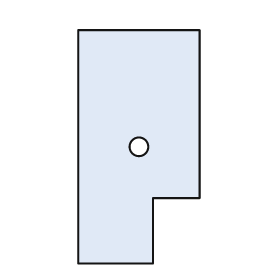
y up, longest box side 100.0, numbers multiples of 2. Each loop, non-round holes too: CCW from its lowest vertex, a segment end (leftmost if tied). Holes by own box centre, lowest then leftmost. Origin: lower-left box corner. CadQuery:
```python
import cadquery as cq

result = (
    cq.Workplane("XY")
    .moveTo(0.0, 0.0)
    .lineTo(32.0, 0.0)
    .lineTo(32.0, 28.0)
    .lineTo(52.0, 28.0)
    .lineTo(52.0, 100.0)
    .lineTo(0.0, 100.0)
    .close()
    .moveTo(26.0, 50.0)
    .circle(4.0)
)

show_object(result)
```